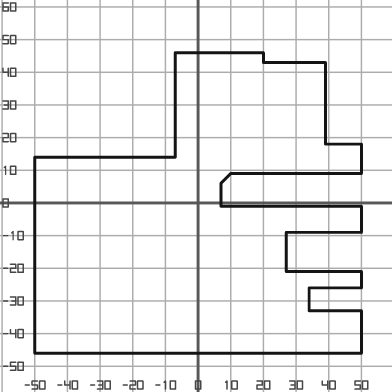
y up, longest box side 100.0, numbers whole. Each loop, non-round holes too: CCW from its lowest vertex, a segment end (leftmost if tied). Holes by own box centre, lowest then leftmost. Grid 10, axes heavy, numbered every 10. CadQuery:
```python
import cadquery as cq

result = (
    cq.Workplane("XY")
    .moveTo(-50.0, -46.0)
    .lineTo(50.0, -46.0)
    .lineTo(50.0, -33.0)
    .lineTo(34.0, -33.0)
    .lineTo(34.0, -26.0)
    .lineTo(50.0, -26.0)
    .lineTo(50.0, -21.0)
    .lineTo(27.0, -21.0)
    .lineTo(27.0, -9.0)
    .lineTo(50.0, -9.0)
    .lineTo(50.0, -1.0)
    .lineTo(7.0, -1.0)
    .lineTo(7.0, 6.0)
    .lineTo(10.0, 9.0)
    .lineTo(50.0, 9.0)
    .lineTo(50.0, 18.0)
    .lineTo(39.0, 18.0)
    .lineTo(39.0, 43.0)
    .lineTo(20.0, 43.0)
    .lineTo(20.0, 46.0)
    .lineTo(-7.0, 46.0)
    .lineTo(-7.0, 14.0)
    .lineTo(-50.0, 14.0)
    .close()
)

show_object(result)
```